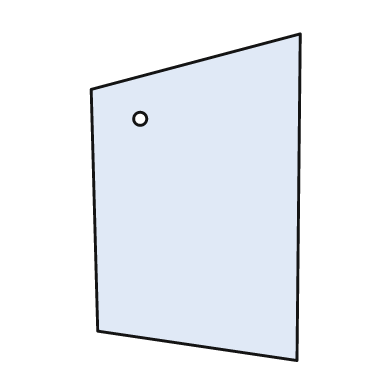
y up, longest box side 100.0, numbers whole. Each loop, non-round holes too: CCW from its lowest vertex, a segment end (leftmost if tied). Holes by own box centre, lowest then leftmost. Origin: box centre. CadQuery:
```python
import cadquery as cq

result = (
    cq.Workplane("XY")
    .moveTo(31.0, -50.0)
    .lineTo(32.0, 50.0)
    .lineTo(-32.0, 33.0)
    .lineTo(-30.0, -41.0)
    .close()
    .moveTo(-17.0, 24.0)
    .circle(2.0)
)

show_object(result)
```